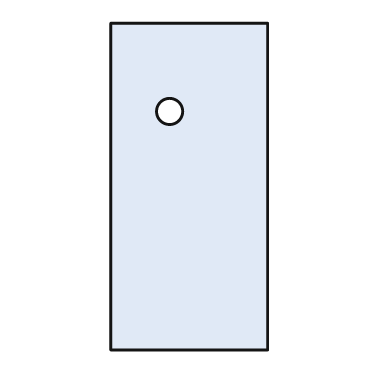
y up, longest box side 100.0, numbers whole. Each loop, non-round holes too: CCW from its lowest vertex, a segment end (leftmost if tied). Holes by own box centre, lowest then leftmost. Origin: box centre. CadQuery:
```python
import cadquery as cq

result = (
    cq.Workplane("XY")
    .moveTo(-24.0, -50.0)
    .lineTo(24.0, -50.0)
    .lineTo(24.0, 50.0)
    .lineTo(-24.0, 50.0)
    .close()
    .moveTo(-6.0, 23.0)
    .circle(4.0)
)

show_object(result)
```